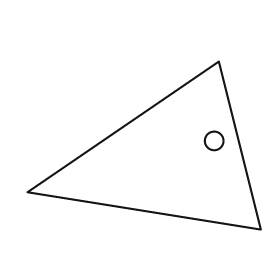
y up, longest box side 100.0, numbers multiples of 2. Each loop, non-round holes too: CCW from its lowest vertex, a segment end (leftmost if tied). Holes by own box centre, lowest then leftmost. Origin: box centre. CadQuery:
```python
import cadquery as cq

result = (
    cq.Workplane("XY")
    .moveTo(50.0, -36.0)
    .lineTo(32.0, 36.0)
    .lineTo(-50.0, -20.0)
    .close()
    .moveTo(30.0, 2.0)
    .circle(4.0)
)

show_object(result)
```